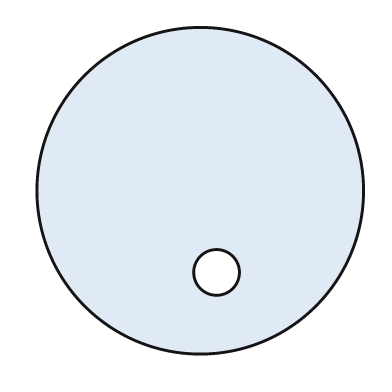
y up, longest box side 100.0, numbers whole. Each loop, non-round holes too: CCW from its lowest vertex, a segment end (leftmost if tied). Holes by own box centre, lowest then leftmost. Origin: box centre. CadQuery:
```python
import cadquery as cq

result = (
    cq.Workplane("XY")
    .moveTo(0.0, 0.0)
    .circle(50.0)
    .moveTo(5.0, -25.0)
    .circle(7.0)
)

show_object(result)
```